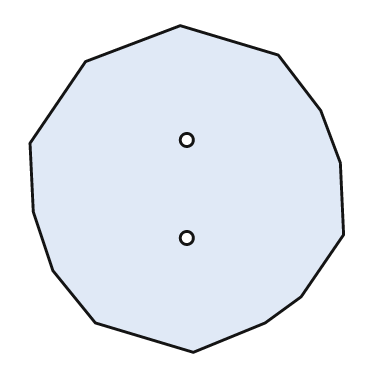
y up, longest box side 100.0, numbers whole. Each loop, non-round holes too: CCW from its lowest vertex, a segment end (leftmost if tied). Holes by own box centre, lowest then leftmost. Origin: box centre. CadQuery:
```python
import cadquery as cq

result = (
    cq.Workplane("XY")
    .moveTo(2.0, -50.0)
    .lineTo(24.0, -41.0)
    .lineTo(35.0, -33.0)
    .lineTo(48.0, -14.0)
    .lineTo(47.0, 8.0)
    .lineTo(41.0, 24.0)
    .lineTo(28.0, 41.0)
    .lineTo(-2.0, 50.0)
    .lineTo(-31.0, 39.0)
    .lineTo(-48.0, 14.0)
    .lineTo(-47.0, -7.0)
    .lineTo(-41.0, -25.0)
    .lineTo(-28.0, -41.0)
    .close()
    .moveTo(0.0, -15.0)
    .circle(2.0)
    .moveTo(0.0, 15.0)
    .circle(2.0)
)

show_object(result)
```